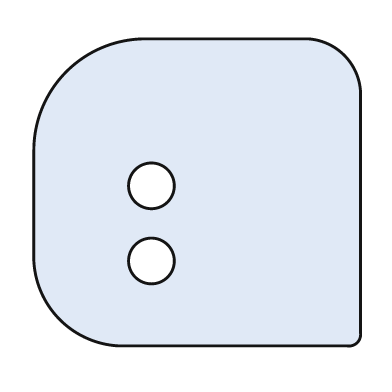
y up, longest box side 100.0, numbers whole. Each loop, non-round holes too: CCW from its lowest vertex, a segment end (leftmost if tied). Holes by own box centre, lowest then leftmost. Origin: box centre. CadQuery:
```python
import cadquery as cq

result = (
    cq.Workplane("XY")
    .moveTo(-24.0, -47.0)
    .lineTo(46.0, -47.0)
    .threePointArc((49.0, -46.0), (50.0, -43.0))
    .lineTo(50.0, 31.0)
    .threePointArc((45.0, 42.0), (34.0, 47.0))
    .lineTo(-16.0, 47.0)
    .threePointArc((-40.0, 37.0), (-50.0, 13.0))
    .lineTo(-50.0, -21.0)
    .threePointArc((-42.0, -39.0), (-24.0, -47.0))
    .close()
    .moveTo(-14.0, -21.0)
    .circle(7.0)
    .moveTo(-14.0, 2.0)
    .circle(7.0)
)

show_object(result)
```